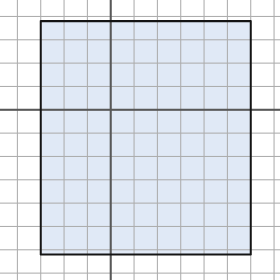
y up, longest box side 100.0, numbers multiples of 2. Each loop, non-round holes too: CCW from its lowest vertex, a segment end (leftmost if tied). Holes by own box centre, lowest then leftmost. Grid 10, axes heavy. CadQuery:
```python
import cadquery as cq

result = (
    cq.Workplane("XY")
    .moveTo(-30.0, -62.0)
    .lineTo(60.0, -62.0)
    .lineTo(60.0, 38.0)
    .lineTo(-30.0, 38.0)
    .close()
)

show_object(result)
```